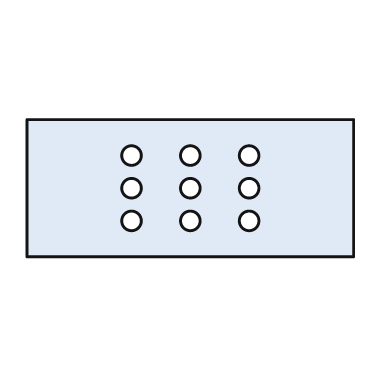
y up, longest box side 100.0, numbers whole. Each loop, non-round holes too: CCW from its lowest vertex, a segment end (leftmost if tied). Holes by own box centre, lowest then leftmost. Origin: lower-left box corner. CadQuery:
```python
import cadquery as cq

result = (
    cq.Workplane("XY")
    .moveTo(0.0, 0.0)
    .lineTo(100.0, 0.0)
    .lineTo(100.0, 42.0)
    .lineTo(0.0, 42.0)
    .close()
    .moveTo(32.0, 11.0)
    .circle(3.0)
    .moveTo(50.0, 11.0)
    .circle(3.0)
    .moveTo(68.0, 11.0)
    .circle(3.0)
    .moveTo(32.0, 21.0)
    .circle(3.0)
    .moveTo(50.0, 21.0)
    .circle(3.0)
    .moveTo(68.0, 21.0)
    .circle(3.0)
    .moveTo(32.0, 31.0)
    .circle(3.0)
    .moveTo(50.0, 31.0)
    .circle(3.0)
    .moveTo(68.0, 31.0)
    .circle(3.0)
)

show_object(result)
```